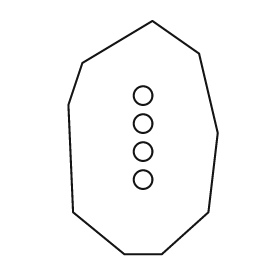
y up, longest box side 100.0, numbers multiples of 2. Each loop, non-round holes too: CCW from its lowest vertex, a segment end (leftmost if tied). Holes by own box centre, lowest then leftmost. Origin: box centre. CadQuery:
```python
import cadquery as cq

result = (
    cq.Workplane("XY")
    .moveTo(-8.0, -50.0)
    .lineTo(8.0, -50.0)
    .lineTo(28.0, -32.0)
    .lineTo(32.0, 2.0)
    .lineTo(24.0, 36.0)
    .lineTo(4.0, 50.0)
    .lineTo(-26.0, 32.0)
    .lineTo(-32.0, 14.0)
    .lineTo(-30.0, -32.0)
    .close()
    .moveTo(0.0, -18.0)
    .circle(4.0)
    .moveTo(0.0, -6.0)
    .circle(4.0)
    .moveTo(0.0, 6.0)
    .circle(4.0)
    .moveTo(0.0, 18.0)
    .circle(4.0)
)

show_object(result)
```